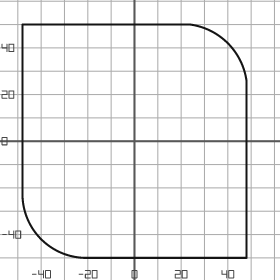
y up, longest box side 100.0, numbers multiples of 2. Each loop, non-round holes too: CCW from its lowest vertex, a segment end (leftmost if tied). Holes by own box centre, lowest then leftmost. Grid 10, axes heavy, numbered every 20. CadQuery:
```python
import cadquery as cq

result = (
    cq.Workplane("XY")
    .moveTo(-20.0, -50.0)
    .lineTo(48.0, -50.0)
    .lineTo(48.0, 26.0)
    .threePointArc((40.0, 42.0), (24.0, 50.0))
    .lineTo(-48.0, 50.0)
    .lineTo(-48.0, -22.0)
    .threePointArc((-40.0, -42.0), (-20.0, -50.0))
    .close()
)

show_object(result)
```